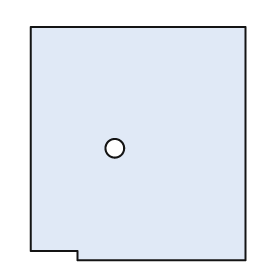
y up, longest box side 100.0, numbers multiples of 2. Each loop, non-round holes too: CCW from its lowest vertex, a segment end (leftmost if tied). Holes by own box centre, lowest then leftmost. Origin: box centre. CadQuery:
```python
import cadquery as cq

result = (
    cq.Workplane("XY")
    .moveTo(-26.0, -50.0)
    .lineTo(46.0, -50.0)
    .lineTo(46.0, 50.0)
    .lineTo(-46.0, 50.0)
    .lineTo(-46.0, -46.0)
    .lineTo(-26.0, -46.0)
    .close()
    .moveTo(-10.0, -2.0)
    .circle(4.0)
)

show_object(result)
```